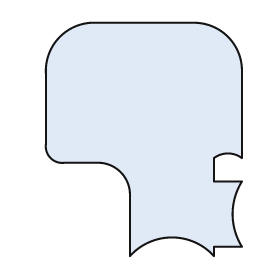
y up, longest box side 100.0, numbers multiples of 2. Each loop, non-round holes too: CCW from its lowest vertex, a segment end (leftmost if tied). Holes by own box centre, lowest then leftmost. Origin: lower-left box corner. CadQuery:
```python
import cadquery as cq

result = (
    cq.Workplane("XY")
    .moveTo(36.0, 0.0)
    .threePointArc((54.0, 8.0), (72.0, 0.0))
    .lineTo(72.0, 4.0)
    .lineTo(84.0, 4.0)
    .threePointArc((80.0, 18.0), (84.0, 32.0))
    .lineTo(72.0, 32.0)
    .lineTo(72.0, 42.0)
    .threePointArc((78.0, 44.0), (84.0, 42.0))
    .lineTo(84.0, 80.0)
    .threePointArc((78.0, 94.0), (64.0, 100.0))
    .lineTo(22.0, 100.0)
    .threePointArc((6.0, 94.0), (0.0, 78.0))
    .lineTo(0.0, 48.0)
    .threePointArc((2.0, 42.0), (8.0, 40.0))
    .lineTo(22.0, 40.0)
    .threePointArc((32.0, 36.0), (36.0, 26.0))
    .close()
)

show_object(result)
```